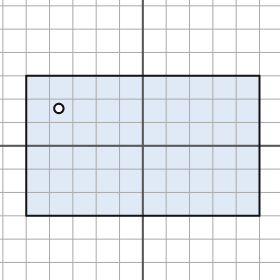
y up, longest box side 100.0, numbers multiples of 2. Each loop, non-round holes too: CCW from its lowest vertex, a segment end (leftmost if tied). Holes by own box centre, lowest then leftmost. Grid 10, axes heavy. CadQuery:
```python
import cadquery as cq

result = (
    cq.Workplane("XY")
    .moveTo(-50.0, -30.0)
    .lineTo(50.0, -30.0)
    .lineTo(50.0, 30.0)
    .lineTo(-50.0, 30.0)
    .close()
    .moveTo(-36.0, 16.0)
    .circle(2.0)
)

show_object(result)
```